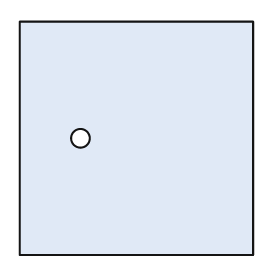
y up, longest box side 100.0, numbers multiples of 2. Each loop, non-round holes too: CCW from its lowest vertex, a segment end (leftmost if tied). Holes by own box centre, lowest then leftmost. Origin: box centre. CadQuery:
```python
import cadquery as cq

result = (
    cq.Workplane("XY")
    .moveTo(-50.0, -50.0)
    .lineTo(50.0, -50.0)
    .lineTo(50.0, 50.0)
    .lineTo(-50.0, 50.0)
    .close()
    .moveTo(-24.0, 0.0)
    .circle(4.0)
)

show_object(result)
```